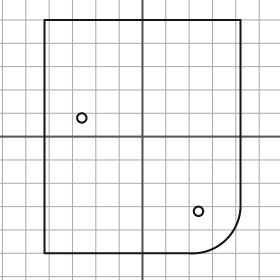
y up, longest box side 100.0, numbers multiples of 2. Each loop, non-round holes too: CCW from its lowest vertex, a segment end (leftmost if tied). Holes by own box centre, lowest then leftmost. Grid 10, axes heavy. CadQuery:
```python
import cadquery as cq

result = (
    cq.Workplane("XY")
    .moveTo(-42.0, -50.0)
    .lineTo(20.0, -50.0)
    .threePointArc((36.0, -44.0), (42.0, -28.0))
    .lineTo(42.0, 50.0)
    .lineTo(-42.0, 50.0)
    .close()
    .moveTo(24.0, -32.0)
    .circle(2.0)
    .moveTo(-26.0, 8.0)
    .circle(2.0)
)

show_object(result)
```